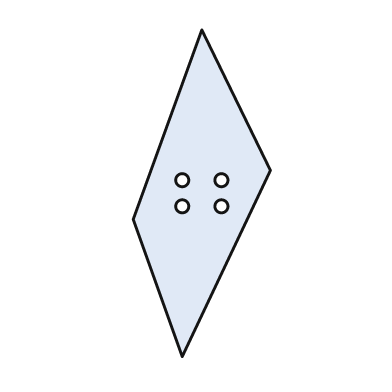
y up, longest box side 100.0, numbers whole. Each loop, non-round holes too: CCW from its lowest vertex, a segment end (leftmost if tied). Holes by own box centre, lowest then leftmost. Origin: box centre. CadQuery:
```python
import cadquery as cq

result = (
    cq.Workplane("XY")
    .moveTo(-6.0, -50.0)
    .lineTo(21.0, 7.0)
    .lineTo(0.0, 50.0)
    .lineTo(-21.0, -8.0)
    .close()
    .moveTo(-6.0, -4.0)
    .circle(2.0)
    .moveTo(6.0, -4.0)
    .circle(2.0)
    .moveTo(-6.0, 4.0)
    .circle(2.0)
    .moveTo(6.0, 4.0)
    .circle(2.0)
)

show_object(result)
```